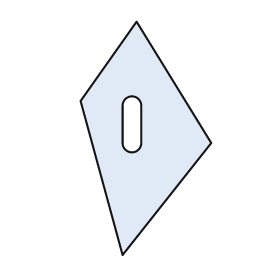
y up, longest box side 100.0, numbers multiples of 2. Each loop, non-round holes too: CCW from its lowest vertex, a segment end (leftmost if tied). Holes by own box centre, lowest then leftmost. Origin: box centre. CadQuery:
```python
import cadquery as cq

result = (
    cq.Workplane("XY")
    .moveTo(-10.0, -50.0)
    .lineTo(28.0, -2.0)
    .lineTo(-4.0, 50.0)
    .lineTo(-28.0, 16.0)
    .close()
    .moveTo(-10.0, -2.0)
    .threePointArc((-6.0, -6.0), (-2.0, -2.0))
    .lineTo(-2.0, 14.0)
    .threePointArc((-6.0, 18.0), (-10.0, 14.0))
    .close()
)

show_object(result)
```